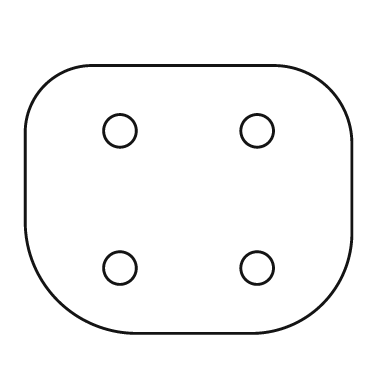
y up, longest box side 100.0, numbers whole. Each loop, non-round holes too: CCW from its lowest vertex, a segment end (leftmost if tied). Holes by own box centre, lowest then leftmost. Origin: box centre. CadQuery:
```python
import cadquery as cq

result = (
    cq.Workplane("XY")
    .moveTo(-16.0, -41.0)
    .lineTo(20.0, -41.0)
    .threePointArc((41.0, -32.0), (50.0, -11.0))
    .lineTo(50.0, 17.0)
    .threePointArc((43.0, 34.0), (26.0, 41.0))
    .lineTo(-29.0, 41.0)
    .threePointArc((-44.0, 35.0), (-50.0, 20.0))
    .lineTo(-50.0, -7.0)
    .threePointArc((-40.0, -31.0), (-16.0, -41.0))
    .close()
    .moveTo(-21.0, -21.0)
    .circle(5.0)
    .moveTo(21.0, -21.0)
    .circle(5.0)
    .moveTo(-21.0, 21.0)
    .circle(5.0)
    .moveTo(21.0, 21.0)
    .circle(5.0)
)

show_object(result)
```